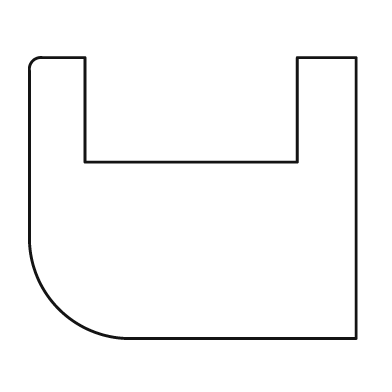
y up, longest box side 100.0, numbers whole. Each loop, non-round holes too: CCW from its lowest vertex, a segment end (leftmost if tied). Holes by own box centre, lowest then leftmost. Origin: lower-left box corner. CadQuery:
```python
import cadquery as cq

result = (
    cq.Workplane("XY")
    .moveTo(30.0, 0.0)
    .lineTo(100.0, 0.0)
    .lineTo(100.0, 86.0)
    .lineTo(82.0, 86.0)
    .lineTo(82.0, 54.0)
    .lineTo(17.0, 54.0)
    .lineTo(17.0, 86.0)
    .lineTo(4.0, 86.0)
    .threePointArc((1.0, 85.0), (0.0, 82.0))
    .lineTo(0.0, 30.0)
    .threePointArc((9.0, 9.0), (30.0, 0.0))
    .close()
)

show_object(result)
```